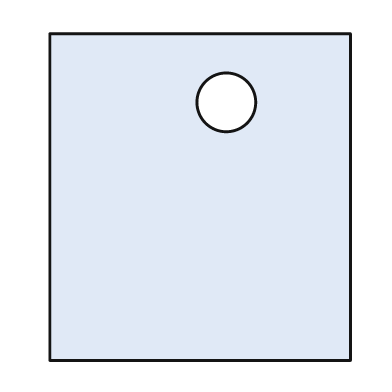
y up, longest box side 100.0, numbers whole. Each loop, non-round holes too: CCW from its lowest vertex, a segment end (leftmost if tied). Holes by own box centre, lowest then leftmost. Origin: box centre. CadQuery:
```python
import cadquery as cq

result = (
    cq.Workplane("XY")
    .moveTo(-46.0, -50.0)
    .lineTo(46.0, -50.0)
    .lineTo(46.0, 50.0)
    .lineTo(-46.0, 50.0)
    .close()
    .moveTo(8.0, 29.0)
    .circle(9.0)
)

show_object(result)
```